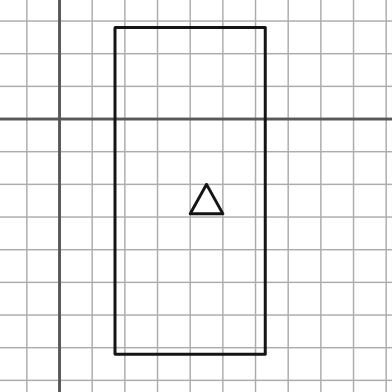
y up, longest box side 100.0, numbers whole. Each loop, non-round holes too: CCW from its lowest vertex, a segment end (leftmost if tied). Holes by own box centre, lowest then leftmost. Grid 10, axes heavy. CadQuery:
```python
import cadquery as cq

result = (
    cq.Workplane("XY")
    .moveTo(17.0, -72.0)
    .lineTo(63.0, -72.0)
    .lineTo(63.0, 28.0)
    .lineTo(17.0, 28.0)
    .close()
    .moveTo(40.0, -29.0)
    .lineTo(50.0, -29.0)
    .lineTo(45.0, -20.0)
    .close()
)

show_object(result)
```